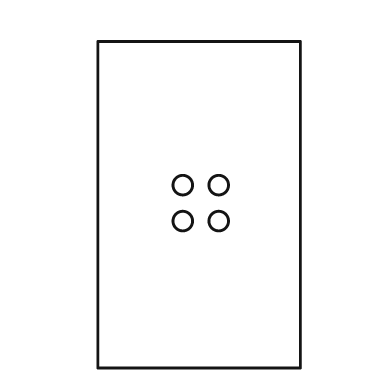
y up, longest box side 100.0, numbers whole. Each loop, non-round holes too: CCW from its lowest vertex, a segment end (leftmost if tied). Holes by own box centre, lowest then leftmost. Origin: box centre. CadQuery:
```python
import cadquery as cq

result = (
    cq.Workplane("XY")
    .moveTo(-31.0, -50.0)
    .lineTo(31.0, -50.0)
    .lineTo(31.0, 50.0)
    .lineTo(-31.0, 50.0)
    .close()
    .moveTo(-5.0, -5.0)
    .circle(3.0)
    .moveTo(6.0, -5.0)
    .circle(3.0)
    .moveTo(-5.0, 6.0)
    .circle(3.0)
    .moveTo(6.0, 6.0)
    .circle(3.0)
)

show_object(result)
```